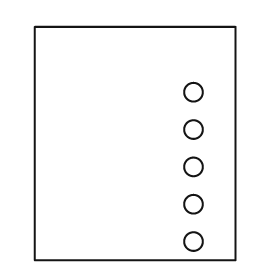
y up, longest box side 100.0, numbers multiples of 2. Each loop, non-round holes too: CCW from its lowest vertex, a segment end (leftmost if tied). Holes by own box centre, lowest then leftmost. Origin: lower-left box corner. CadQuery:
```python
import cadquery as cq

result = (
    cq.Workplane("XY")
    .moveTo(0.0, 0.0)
    .lineTo(86.0, 0.0)
    .lineTo(86.0, 100.0)
    .lineTo(0.0, 100.0)
    .close()
    .moveTo(68.0, 8.0)
    .circle(4.0)
    .moveTo(68.0, 24.0)
    .circle(4.0)
    .moveTo(68.0, 40.0)
    .circle(4.0)
    .moveTo(68.0, 56.0)
    .circle(4.0)
    .moveTo(68.0, 72.0)
    .circle(4.0)
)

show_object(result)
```